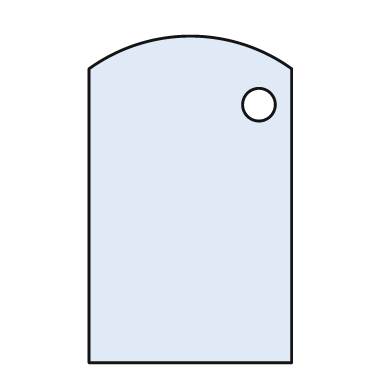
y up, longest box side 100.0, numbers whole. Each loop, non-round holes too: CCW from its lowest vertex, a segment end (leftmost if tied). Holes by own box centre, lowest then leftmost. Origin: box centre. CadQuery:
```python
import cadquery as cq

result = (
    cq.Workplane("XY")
    .moveTo(-31.0, -50.0)
    .lineTo(31.0, -50.0)
    .lineTo(31.0, 40.0)
    .threePointArc((0.0, 50.0), (-31.0, 40.0))
    .close()
    .moveTo(21.0, 29.0)
    .circle(5.0)
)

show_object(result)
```